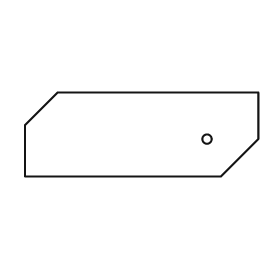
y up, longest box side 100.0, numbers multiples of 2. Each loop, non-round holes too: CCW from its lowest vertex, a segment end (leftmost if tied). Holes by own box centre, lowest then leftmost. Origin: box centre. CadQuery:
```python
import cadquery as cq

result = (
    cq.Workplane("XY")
    .moveTo(-50.0, -18.0)
    .lineTo(34.0, -18.0)
    .lineTo(50.0, -2.0)
    .lineTo(50.0, 18.0)
    .lineTo(-36.0, 18.0)
    .lineTo(-50.0, 4.0)
    .close()
    .moveTo(28.0, -2.0)
    .circle(2.0)
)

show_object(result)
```